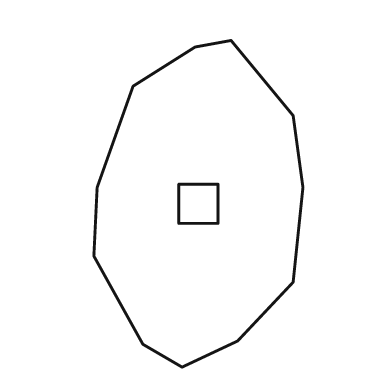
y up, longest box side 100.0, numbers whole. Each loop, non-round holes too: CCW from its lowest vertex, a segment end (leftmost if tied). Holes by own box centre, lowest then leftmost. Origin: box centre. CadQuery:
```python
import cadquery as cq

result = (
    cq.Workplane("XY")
    .moveTo(-5.0, -50.0)
    .lineTo(12.0, -42.0)
    .lineTo(29.0, -24.0)
    .lineTo(32.0, 5.0)
    .lineTo(29.0, 27.0)
    .lineTo(10.0, 50.0)
    .lineTo(-1.0, 48.0)
    .lineTo(-20.0, 36.0)
    .lineTo(-31.0, 5.0)
    .lineTo(-32.0, -16.0)
    .lineTo(-17.0, -43.0)
    .close()
    .moveTo(-6.0, -6.0)
    .lineTo(6.0, -6.0)
    .lineTo(6.0, 6.0)
    .lineTo(-6.0, 6.0)
    .close()
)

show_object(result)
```